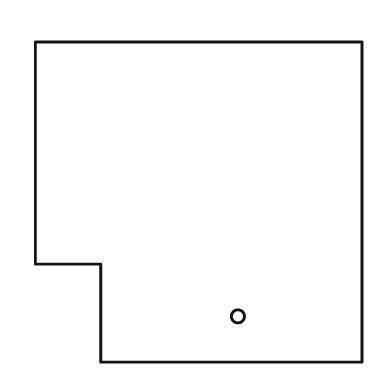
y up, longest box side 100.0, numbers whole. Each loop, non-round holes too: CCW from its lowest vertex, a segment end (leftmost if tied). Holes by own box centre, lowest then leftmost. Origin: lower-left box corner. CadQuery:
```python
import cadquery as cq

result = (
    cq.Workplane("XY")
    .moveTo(20.0, 0.0)
    .lineTo(100.0, 0.0)
    .lineTo(100.0, 98.0)
    .lineTo(0.0, 98.0)
    .lineTo(0.0, 30.0)
    .lineTo(20.0, 30.0)
    .close()
    .moveTo(62.0, 14.0)
    .circle(2.0)
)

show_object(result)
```